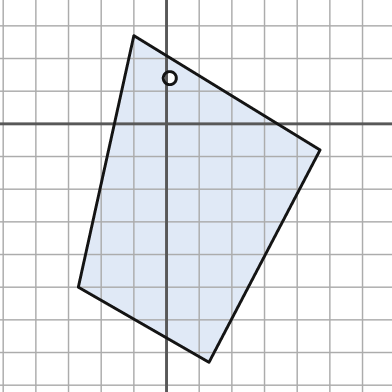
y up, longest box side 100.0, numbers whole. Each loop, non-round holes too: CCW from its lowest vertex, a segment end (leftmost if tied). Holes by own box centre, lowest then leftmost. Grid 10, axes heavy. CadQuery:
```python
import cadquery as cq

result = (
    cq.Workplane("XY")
    .moveTo(13.0, -73.0)
    .lineTo(47.0, -8.0)
    .lineTo(-10.0, 27.0)
    .lineTo(-27.0, -50.0)
    .close()
    .moveTo(1.0, 14.0)
    .circle(2.0)
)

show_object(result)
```